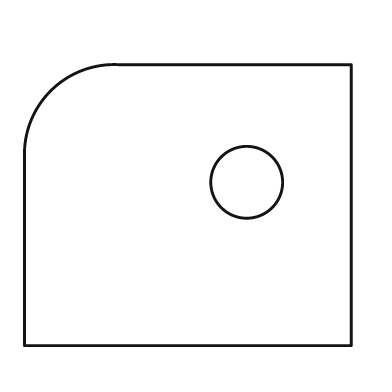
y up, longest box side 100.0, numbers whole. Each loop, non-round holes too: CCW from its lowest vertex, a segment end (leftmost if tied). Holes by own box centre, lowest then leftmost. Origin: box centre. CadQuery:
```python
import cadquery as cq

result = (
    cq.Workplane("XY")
    .moveTo(-50.0, -43.0)
    .lineTo(50.0, -43.0)
    .lineTo(50.0, 43.0)
    .lineTo(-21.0, 43.0)
    .threePointArc((-42.0, 35.0), (-50.0, 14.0))
    .close()
    .moveTo(18.0, 7.0)
    .circle(11.0)
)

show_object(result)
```